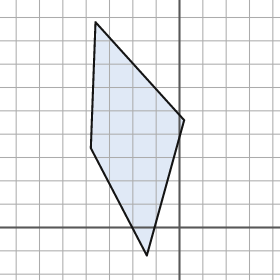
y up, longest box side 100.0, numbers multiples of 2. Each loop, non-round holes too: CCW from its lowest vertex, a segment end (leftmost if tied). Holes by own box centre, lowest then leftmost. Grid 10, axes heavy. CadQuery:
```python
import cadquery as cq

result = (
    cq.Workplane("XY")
    .moveTo(-14.0, -12.0)
    .lineTo(2.0, 46.0)
    .lineTo(-36.0, 88.0)
    .lineTo(-38.0, 34.0)
    .close()
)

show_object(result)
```